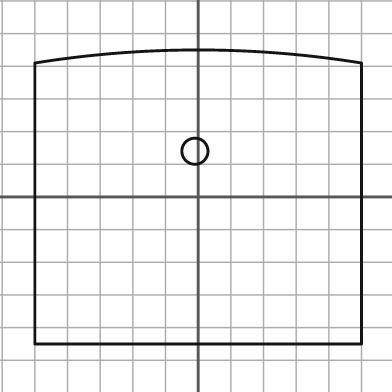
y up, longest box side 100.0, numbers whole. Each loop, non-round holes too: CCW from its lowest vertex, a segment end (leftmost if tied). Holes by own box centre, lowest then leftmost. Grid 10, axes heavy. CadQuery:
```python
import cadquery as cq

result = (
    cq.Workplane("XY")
    .moveTo(-50.0, -45.0)
    .lineTo(50.0, -45.0)
    .lineTo(50.0, 41.0)
    .threePointArc((0.0, 45.0), (-50.0, 41.0))
    .close()
    .moveTo(-1.0, 14.0)
    .circle(4.0)
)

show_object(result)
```